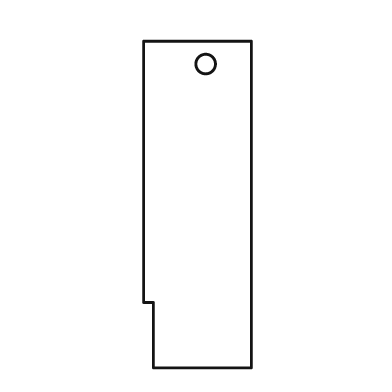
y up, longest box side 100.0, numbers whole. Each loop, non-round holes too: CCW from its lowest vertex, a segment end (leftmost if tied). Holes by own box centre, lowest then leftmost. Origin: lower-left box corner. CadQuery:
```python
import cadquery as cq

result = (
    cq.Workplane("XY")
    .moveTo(3.0, 0.0)
    .lineTo(33.0, 0.0)
    .lineTo(33.0, 100.0)
    .lineTo(0.0, 100.0)
    .lineTo(0.0, 20.0)
    .lineTo(3.0, 20.0)
    .close()
    .moveTo(19.0, 93.0)
    .circle(3.0)
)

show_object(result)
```